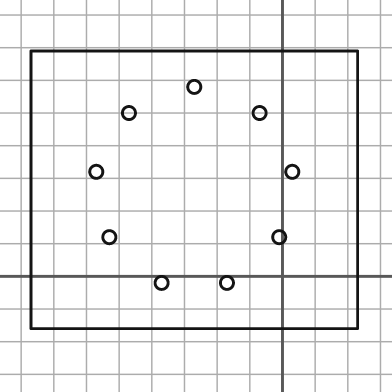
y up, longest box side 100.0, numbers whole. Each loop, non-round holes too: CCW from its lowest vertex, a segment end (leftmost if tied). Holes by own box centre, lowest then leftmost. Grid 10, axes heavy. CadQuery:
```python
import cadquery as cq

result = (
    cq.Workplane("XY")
    .moveTo(-77.0, -16.0)
    .lineTo(23.0, -16.0)
    .lineTo(23.0, 69.0)
    .lineTo(-77.0, 69.0)
    .close()
    .moveTo(-37.0, -2.0)
    .circle(2.0)
    .moveTo(-17.0, -2.0)
    .circle(2.0)
    .moveTo(-53.0, 12.0)
    .circle(2.0)
    .moveTo(-1.0, 12.0)
    .circle(2.0)
    .moveTo(-57.0, 32.0)
    .circle(2.0)
    .moveTo(3.0, 32.0)
    .circle(2.0)
    .moveTo(-47.0, 50.0)
    .circle(2.0)
    .moveTo(-7.0, 50.0)
    .circle(2.0)
    .moveTo(-27.0, 58.0)
    .circle(2.0)
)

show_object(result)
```